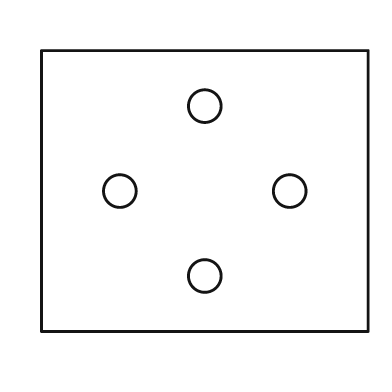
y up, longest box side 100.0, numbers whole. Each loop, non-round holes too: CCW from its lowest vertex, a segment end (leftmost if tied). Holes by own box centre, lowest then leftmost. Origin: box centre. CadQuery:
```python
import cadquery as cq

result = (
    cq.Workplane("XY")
    .moveTo(-50.0, -43.0)
    .lineTo(50.0, -43.0)
    .lineTo(50.0, 43.0)
    .lineTo(-50.0, 43.0)
    .close()
    .moveTo(0.0, -26.0)
    .circle(5.0)
    .moveTo(-26.0, 0.0)
    .circle(5.0)
    .moveTo(26.0, 0.0)
    .circle(5.0)
    .moveTo(0.0, 26.0)
    .circle(5.0)
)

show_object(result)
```